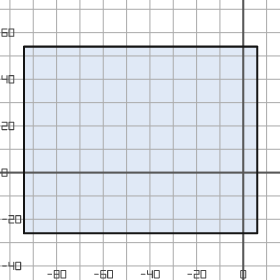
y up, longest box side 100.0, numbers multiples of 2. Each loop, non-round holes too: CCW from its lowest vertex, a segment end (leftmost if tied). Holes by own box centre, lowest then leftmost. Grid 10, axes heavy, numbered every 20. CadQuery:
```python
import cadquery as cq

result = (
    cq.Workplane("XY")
    .moveTo(-94.0, -26.0)
    .lineTo(6.0, -26.0)
    .lineTo(6.0, 54.0)
    .lineTo(-94.0, 54.0)
    .close()
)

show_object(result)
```